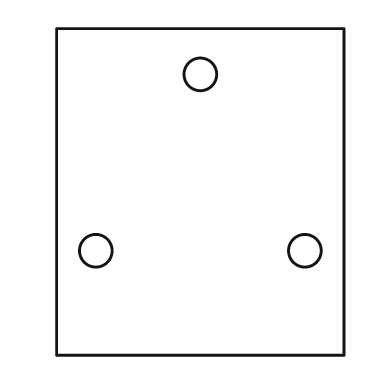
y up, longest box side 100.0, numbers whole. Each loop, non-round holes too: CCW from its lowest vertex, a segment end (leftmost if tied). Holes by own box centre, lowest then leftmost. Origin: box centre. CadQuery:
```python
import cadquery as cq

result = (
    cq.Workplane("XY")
    .moveTo(-44.0, -50.0)
    .lineTo(44.0, -50.0)
    .lineTo(44.0, 50.0)
    .lineTo(-44.0, 50.0)
    .close()
    .moveTo(-32.0, -18.0)
    .circle(5.0)
    .moveTo(32.0, -18.0)
    .circle(5.0)
    .moveTo(0.0, 36.0)
    .circle(5.0)
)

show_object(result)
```